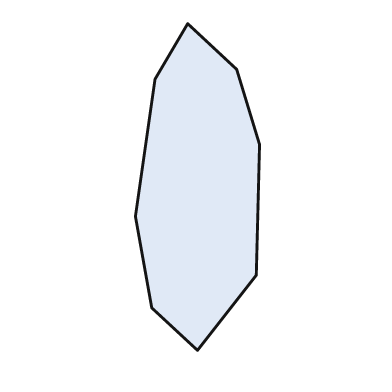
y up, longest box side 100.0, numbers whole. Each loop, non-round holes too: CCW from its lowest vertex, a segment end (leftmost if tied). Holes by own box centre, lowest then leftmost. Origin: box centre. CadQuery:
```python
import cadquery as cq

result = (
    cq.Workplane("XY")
    .moveTo(0.0, -50.0)
    .lineTo(18.0, -27.0)
    .lineTo(19.0, 13.0)
    .lineTo(12.0, 36.0)
    .lineTo(-3.0, 50.0)
    .lineTo(-13.0, 33.0)
    .lineTo(-19.0, -9.0)
    .lineTo(-14.0, -37.0)
    .close()
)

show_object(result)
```